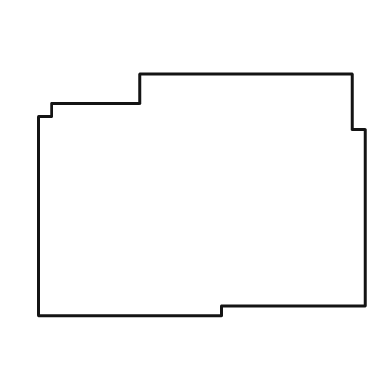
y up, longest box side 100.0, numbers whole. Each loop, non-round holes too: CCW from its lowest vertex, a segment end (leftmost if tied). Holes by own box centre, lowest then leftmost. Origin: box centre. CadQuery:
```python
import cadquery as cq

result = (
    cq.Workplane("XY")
    .moveTo(-50.0, -37.0)
    .lineTo(6.0, -37.0)
    .lineTo(6.0, -34.0)
    .lineTo(50.0, -34.0)
    .lineTo(50.0, 20.0)
    .lineTo(46.0, 20.0)
    .lineTo(46.0, 37.0)
    .lineTo(-19.0, 37.0)
    .lineTo(-19.0, 28.0)
    .lineTo(-46.0, 28.0)
    .lineTo(-46.0, 24.0)
    .lineTo(-50.0, 24.0)
    .close()
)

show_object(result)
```